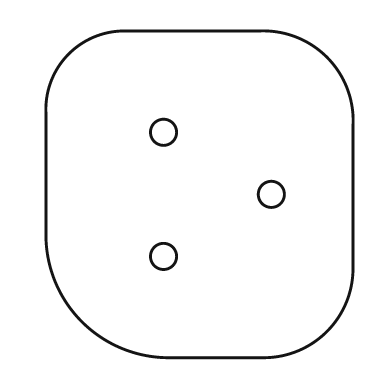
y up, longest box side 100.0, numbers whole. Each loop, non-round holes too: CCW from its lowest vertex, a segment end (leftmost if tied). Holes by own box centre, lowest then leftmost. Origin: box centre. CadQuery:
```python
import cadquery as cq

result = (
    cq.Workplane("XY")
    .moveTo(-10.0, -50.0)
    .lineTo(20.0, -50.0)
    .threePointArc((39.0, -42.0), (47.0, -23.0))
    .lineTo(47.0, 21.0)
    .threePointArc((39.0, 42.0), (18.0, 50.0))
    .lineTo(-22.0, 50.0)
    .threePointArc((-40.0, 43.0), (-47.0, 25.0))
    .lineTo(-47.0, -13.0)
    .threePointArc((-36.0, -39.0), (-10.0, -50.0))
    .close()
    .moveTo(-11.0, -19.0)
    .circle(4.0)
    .moveTo(22.0, 0.0)
    .circle(4.0)
    .moveTo(-11.0, 19.0)
    .circle(4.0)
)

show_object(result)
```